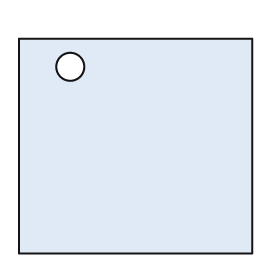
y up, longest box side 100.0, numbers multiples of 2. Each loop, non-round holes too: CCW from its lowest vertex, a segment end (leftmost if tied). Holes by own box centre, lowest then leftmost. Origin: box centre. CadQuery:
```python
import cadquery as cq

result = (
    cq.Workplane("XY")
    .moveTo(-50.0, -46.0)
    .lineTo(50.0, -46.0)
    .lineTo(50.0, 46.0)
    .lineTo(-50.0, 46.0)
    .close()
    .moveTo(-28.0, 34.0)
    .circle(6.0)
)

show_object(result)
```